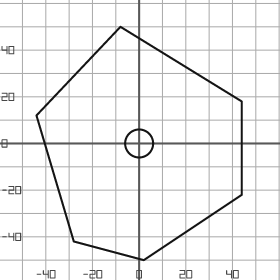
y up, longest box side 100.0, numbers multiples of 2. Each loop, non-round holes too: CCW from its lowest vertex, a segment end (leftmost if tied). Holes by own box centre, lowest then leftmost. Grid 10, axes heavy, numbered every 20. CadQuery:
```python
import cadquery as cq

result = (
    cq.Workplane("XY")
    .moveTo(2.0, -50.0)
    .lineTo(44.0, -22.0)
    .lineTo(44.0, 18.0)
    .lineTo(-8.0, 50.0)
    .lineTo(-44.0, 12.0)
    .lineTo(-28.0, -42.0)
    .close()
    .moveTo(0.0, 0.0)
    .circle(6.0)
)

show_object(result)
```